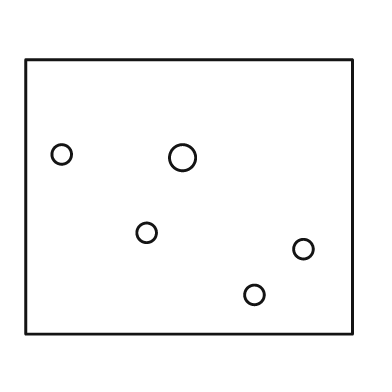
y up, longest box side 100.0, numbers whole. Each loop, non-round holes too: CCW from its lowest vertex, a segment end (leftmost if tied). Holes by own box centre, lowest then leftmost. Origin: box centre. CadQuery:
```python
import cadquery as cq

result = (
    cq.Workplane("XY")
    .moveTo(-50.0, -42.0)
    .lineTo(50.0, -42.0)
    .lineTo(50.0, 42.0)
    .lineTo(-50.0, 42.0)
    .close()
    .moveTo(20.0, -30.0)
    .circle(3.0)
    .moveTo(35.0, -16.0)
    .circle(3.0)
    .moveTo(-13.0, -11.0)
    .circle(3.0)
    .moveTo(-2.0, 12.0)
    .circle(4.0)
    .moveTo(-39.0, 13.0)
    .circle(3.0)
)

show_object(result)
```